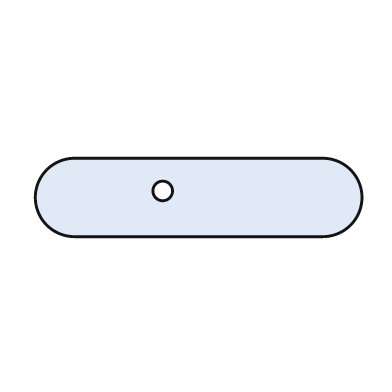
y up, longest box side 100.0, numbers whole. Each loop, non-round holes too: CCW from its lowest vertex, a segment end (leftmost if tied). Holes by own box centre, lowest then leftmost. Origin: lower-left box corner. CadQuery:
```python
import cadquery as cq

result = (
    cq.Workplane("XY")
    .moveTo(12.0, 0.0)
    .lineTo(88.0, 0.0)
    .threePointArc((100.0, 12.0), (88.0, 24.0))
    .lineTo(12.0, 24.0)
    .threePointArc((0.0, 12.0), (12.0, 0.0))
    .close()
    .moveTo(39.0, 14.0)
    .circle(3.0)
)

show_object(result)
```